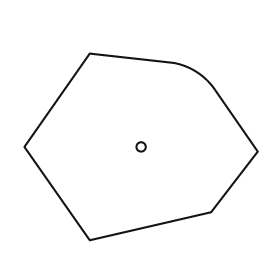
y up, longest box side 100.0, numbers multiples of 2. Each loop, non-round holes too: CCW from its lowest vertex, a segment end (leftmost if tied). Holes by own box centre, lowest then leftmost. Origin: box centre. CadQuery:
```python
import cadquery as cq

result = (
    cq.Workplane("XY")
    .moveTo(-22.0, -40.0)
    .lineTo(30.0, -28.0)
    .lineTo(50.0, -2.0)
    .lineTo(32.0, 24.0)
    .threePointArc((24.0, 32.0), (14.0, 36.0))
    .lineTo(-22.0, 40.0)
    .lineTo(-50.0, 0.0)
    .close()
    .moveTo(0.0, 0.0)
    .circle(2.0)
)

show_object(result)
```